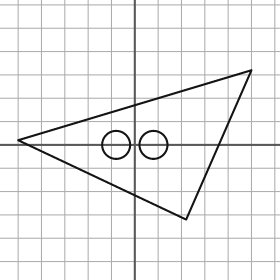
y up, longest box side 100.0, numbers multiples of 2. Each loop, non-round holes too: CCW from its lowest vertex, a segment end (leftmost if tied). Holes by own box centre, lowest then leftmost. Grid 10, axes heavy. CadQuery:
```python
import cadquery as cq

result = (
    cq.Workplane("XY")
    .moveTo(22.0, -32.0)
    .lineTo(50.0, 32.0)
    .lineTo(-50.0, 2.0)
    .close()
    .moveTo(-8.0, 0.0)
    .circle(6.0)
    .moveTo(8.0, 0.0)
    .circle(6.0)
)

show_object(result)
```